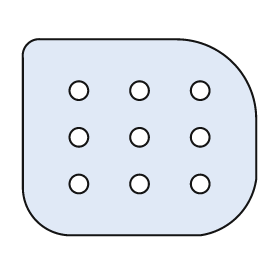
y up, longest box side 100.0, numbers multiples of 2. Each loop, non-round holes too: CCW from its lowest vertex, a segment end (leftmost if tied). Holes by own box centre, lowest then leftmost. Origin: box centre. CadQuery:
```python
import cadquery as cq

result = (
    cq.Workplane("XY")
    .moveTo(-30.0, -42.0)
    .lineTo(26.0, -42.0)
    .threePointArc((42.0, -34.0), (50.0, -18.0))
    .lineTo(50.0, 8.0)
    .threePointArc((40.0, 32.0), (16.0, 42.0))
    .lineTo(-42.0, 42.0)
    .threePointArc((-48.0, 40.0), (-50.0, 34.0))
    .lineTo(-50.0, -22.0)
    .threePointArc((-44.0, -36.0), (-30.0, -42.0))
    .close()
    .moveTo(-26.0, -20.0)
    .circle(4.0)
    .moveTo(0.0, -20.0)
    .circle(4.0)
    .moveTo(26.0, -20.0)
    .circle(4.0)
    .moveTo(-26.0, 0.0)
    .circle(4.0)
    .moveTo(0.0, 0.0)
    .circle(4.0)
    .moveTo(26.0, 0.0)
    .circle(4.0)
    .moveTo(-26.0, 20.0)
    .circle(4.0)
    .moveTo(0.0, 20.0)
    .circle(4.0)
    .moveTo(26.0, 20.0)
    .circle(4.0)
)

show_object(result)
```